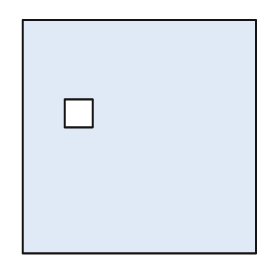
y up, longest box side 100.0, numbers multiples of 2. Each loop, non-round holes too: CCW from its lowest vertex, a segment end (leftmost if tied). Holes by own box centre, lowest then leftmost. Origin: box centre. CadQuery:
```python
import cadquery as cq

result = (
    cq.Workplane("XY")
    .moveTo(-50.0, -50.0)
    .lineTo(50.0, -50.0)
    .lineTo(50.0, 50.0)
    .lineTo(-50.0, 50.0)
    .close()
    .moveTo(-32.0, 4.0)
    .lineTo(-20.0, 4.0)
    .lineTo(-20.0, 16.0)
    .lineTo(-32.0, 16.0)
    .close()
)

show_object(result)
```